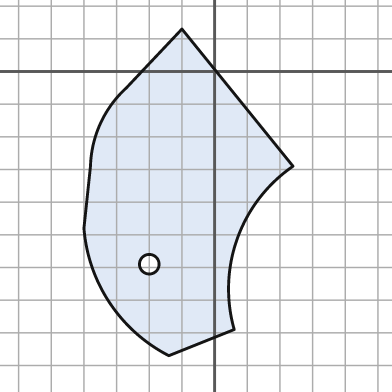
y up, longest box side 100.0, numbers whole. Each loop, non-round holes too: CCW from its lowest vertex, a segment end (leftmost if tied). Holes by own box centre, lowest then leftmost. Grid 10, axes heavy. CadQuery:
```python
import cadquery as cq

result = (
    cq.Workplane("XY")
    .moveTo(-14.0, -87.0)
    .lineTo(6.0, -79.0)
    .threePointArc((7.0, -51.0), (24.0, -29.0))
    .lineTo(-10.0, 13.0)
    .lineTo(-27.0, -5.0)
    .threePointArc((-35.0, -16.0), (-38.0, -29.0))
    .lineTo(-40.0, -48.0)
    .threePointArc((-32.0, -71.0), (-14.0, -87.0))
    .close()
    .moveTo(-20.0, -59.0)
    .circle(3.0)
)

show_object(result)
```